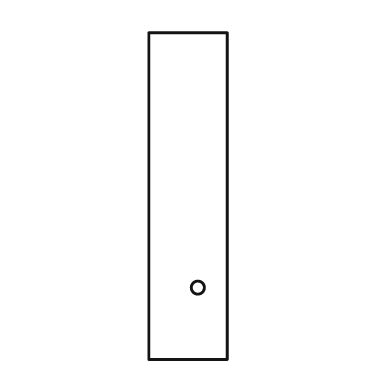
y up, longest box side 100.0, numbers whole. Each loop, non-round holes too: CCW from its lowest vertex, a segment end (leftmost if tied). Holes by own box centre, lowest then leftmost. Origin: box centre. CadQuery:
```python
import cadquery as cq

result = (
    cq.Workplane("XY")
    .moveTo(-12.0, -50.0)
    .lineTo(12.0, -50.0)
    .lineTo(12.0, 50.0)
    .lineTo(-12.0, 50.0)
    .close()
    .moveTo(3.0, -28.0)
    .circle(2.0)
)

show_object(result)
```